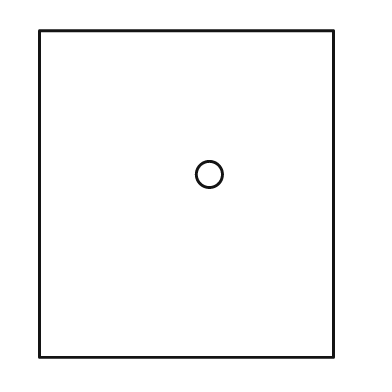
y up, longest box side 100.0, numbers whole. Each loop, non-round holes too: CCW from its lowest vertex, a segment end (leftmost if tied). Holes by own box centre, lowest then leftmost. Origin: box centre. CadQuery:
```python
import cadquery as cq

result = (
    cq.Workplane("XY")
    .moveTo(-45.0, -50.0)
    .lineTo(45.0, -50.0)
    .lineTo(45.0, 50.0)
    .lineTo(-45.0, 50.0)
    .close()
    .moveTo(7.0, 6.0)
    .circle(4.0)
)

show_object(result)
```